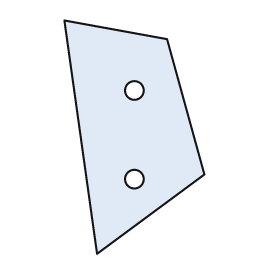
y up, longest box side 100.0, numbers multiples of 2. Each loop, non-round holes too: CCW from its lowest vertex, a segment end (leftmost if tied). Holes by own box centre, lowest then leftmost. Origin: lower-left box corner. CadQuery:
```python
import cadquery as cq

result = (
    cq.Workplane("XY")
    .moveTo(14.0, 0.0)
    .lineTo(60.0, 34.0)
    .lineTo(44.0, 92.0)
    .lineTo(0.0, 100.0)
    .close()
    .moveTo(30.0, 32.0)
    .circle(4.0)
    .moveTo(30.0, 70.0)
    .circle(4.0)
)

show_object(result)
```